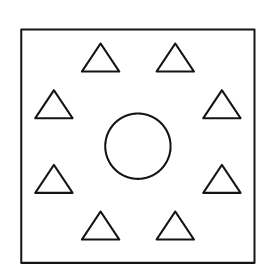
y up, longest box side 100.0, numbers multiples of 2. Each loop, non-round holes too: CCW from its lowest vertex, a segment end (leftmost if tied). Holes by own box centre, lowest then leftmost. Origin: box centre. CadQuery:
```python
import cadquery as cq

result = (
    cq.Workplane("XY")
    .moveTo(-50.0, -50.0)
    .lineTo(50.0, -50.0)
    .lineTo(50.0, 50.0)
    .lineTo(-50.0, 50.0)
    .close()
    .moveTo(-24.0, -40.0)
    .lineTo(-8.0, -40.0)
    .lineTo(-16.0, -28.0)
    .close()
    .moveTo(8.0, -40.0)
    .lineTo(24.0, -40.0)
    .lineTo(16.0, -28.0)
    .close()
    .moveTo(-44.0, -20.0)
    .lineTo(-28.0, -20.0)
    .lineTo(-36.0, -8.0)
    .close()
    .moveTo(28.0, -20.0)
    .lineTo(44.0, -20.0)
    .lineTo(36.0, -8.0)
    .close()
    .moveTo(0.0, 0.0)
    .circle(14.0)
    .moveTo(-44.0, 12.0)
    .lineTo(-28.0, 12.0)
    .lineTo(-36.0, 24.0)
    .close()
    .moveTo(28.0, 12.0)
    .lineTo(44.0, 12.0)
    .lineTo(36.0, 24.0)
    .close()
    .moveTo(-24.0, 32.0)
    .lineTo(-8.0, 32.0)
    .lineTo(-16.0, 44.0)
    .close()
    .moveTo(8.0, 32.0)
    .lineTo(24.0, 32.0)
    .lineTo(16.0, 44.0)
    .close()
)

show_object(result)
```